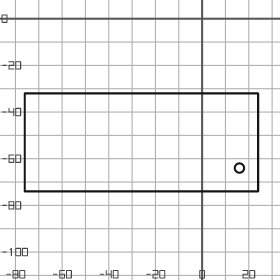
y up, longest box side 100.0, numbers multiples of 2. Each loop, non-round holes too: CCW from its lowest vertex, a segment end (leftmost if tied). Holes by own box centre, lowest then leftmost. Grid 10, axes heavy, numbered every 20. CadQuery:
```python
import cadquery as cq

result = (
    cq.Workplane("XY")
    .moveTo(-76.0, -74.0)
    .lineTo(24.0, -74.0)
    .lineTo(24.0, -32.0)
    .lineTo(-76.0, -32.0)
    .close()
    .moveTo(16.0, -64.0)
    .circle(2.0)
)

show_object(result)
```